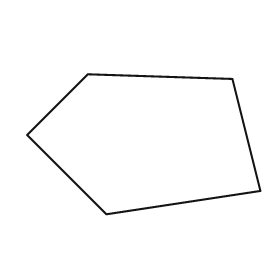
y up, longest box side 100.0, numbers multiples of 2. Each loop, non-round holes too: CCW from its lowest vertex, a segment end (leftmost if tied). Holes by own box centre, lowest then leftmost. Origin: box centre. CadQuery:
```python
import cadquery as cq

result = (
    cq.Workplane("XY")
    .moveTo(-16.0, -30.0)
    .lineTo(50.0, -20.0)
    .lineTo(38.0, 28.0)
    .lineTo(-24.0, 30.0)
    .lineTo(-50.0, 4.0)
    .close()
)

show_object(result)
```